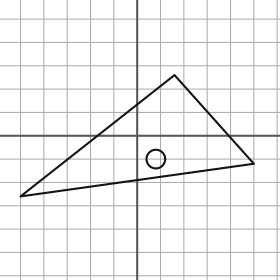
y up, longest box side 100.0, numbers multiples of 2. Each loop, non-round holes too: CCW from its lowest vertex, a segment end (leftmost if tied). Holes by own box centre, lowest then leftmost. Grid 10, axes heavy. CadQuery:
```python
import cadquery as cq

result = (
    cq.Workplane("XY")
    .moveTo(-50.0, -26.0)
    .lineTo(50.0, -12.0)
    .lineTo(16.0, 26.0)
    .close()
    .moveTo(8.0, -10.0)
    .circle(4.0)
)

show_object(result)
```